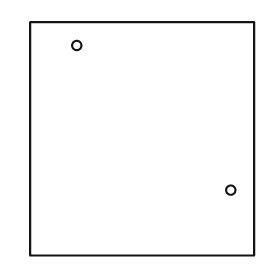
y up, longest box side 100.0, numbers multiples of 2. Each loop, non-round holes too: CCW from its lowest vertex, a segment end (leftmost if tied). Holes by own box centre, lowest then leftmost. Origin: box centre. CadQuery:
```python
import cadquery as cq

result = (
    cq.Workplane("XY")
    .moveTo(-48.0, -50.0)
    .lineTo(48.0, -50.0)
    .lineTo(48.0, 50.0)
    .lineTo(-48.0, 50.0)
    .close()
    .moveTo(38.0, -22.0)
    .circle(2.0)
    .moveTo(-28.0, 40.0)
    .circle(2.0)
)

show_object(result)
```